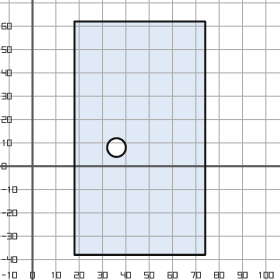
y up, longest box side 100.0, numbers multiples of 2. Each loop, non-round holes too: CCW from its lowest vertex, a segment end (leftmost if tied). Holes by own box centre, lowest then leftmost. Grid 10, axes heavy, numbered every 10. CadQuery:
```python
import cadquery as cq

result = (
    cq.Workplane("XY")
    .moveTo(18.0, -38.0)
    .lineTo(74.0, -38.0)
    .lineTo(74.0, 62.0)
    .lineTo(18.0, 62.0)
    .close()
    .moveTo(36.0, 8.0)
    .circle(4.0)
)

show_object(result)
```